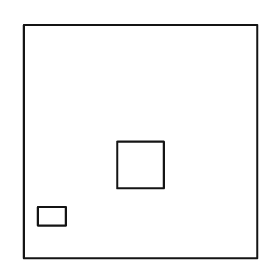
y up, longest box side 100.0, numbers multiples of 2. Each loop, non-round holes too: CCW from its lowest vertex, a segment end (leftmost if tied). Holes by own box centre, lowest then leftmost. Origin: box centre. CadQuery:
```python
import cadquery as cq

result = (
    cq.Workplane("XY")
    .moveTo(-50.0, -50.0)
    .lineTo(50.0, -50.0)
    .lineTo(50.0, 50.0)
    .lineTo(-50.0, 50.0)
    .close()
    .moveTo(-44.0, -36.0)
    .lineTo(-32.0, -36.0)
    .lineTo(-32.0, -28.0)
    .lineTo(-44.0, -28.0)
    .close()
    .moveTo(-10.0, -20.0)
    .lineTo(10.0, -20.0)
    .lineTo(10.0, 0.0)
    .lineTo(-10.0, 0.0)
    .close()
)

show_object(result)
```